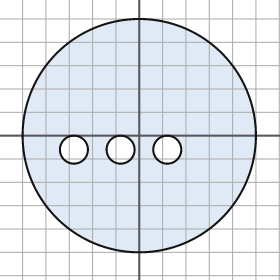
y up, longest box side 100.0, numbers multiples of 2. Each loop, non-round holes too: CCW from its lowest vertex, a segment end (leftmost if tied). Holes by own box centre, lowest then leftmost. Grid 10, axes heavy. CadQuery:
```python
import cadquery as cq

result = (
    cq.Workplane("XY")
    .moveTo(0.0, 0.0)
    .circle(50.0)
    .moveTo(-28.0, -6.0)
    .circle(6.0)
    .moveTo(-8.0, -6.0)
    .circle(6.0)
    .moveTo(12.0, -6.0)
    .circle(6.0)
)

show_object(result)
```